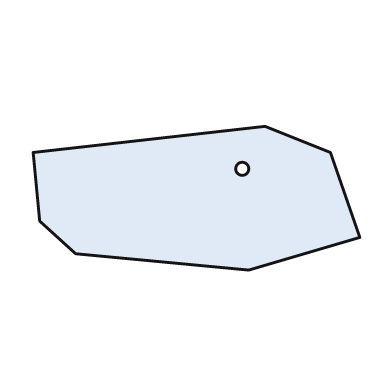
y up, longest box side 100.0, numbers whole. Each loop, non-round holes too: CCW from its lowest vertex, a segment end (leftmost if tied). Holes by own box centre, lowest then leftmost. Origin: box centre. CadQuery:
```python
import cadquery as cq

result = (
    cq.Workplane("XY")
    .moveTo(16.0, -22.0)
    .lineTo(50.0, -12.0)
    .lineTo(41.0, 14.0)
    .lineTo(21.0, 22.0)
    .lineTo(-50.0, 14.0)
    .lineTo(-48.0, -7.0)
    .lineTo(-37.0, -17.0)
    .close()
    .moveTo(14.0, 9.0)
    .circle(2.0)
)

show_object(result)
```